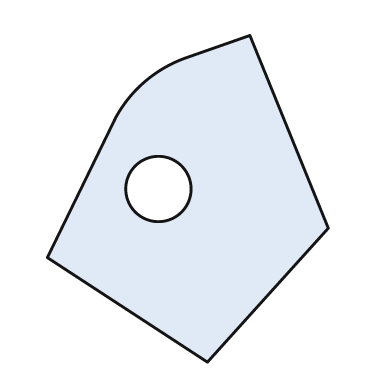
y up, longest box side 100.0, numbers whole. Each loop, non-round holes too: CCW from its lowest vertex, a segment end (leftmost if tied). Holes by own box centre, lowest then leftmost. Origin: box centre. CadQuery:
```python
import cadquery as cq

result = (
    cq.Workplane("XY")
    .moveTo(6.0, -50.0)
    .lineTo(43.0, -9.0)
    .lineTo(19.0, 50.0)
    .lineTo(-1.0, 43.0)
    .threePointArc((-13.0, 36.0), (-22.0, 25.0))
    .lineTo(-43.0, -18.0)
    .close()
    .moveTo(-9.0, 3.0)
    .circle(10.0)
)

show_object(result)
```